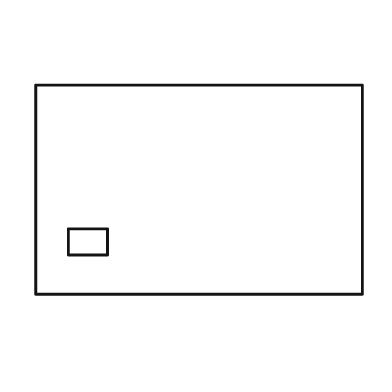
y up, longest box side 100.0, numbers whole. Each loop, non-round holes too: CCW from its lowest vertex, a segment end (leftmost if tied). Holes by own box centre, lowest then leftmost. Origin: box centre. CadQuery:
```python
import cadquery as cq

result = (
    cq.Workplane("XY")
    .moveTo(-50.0, -32.0)
    .lineTo(50.0, -32.0)
    .lineTo(50.0, 32.0)
    .lineTo(-50.0, 32.0)
    .close()
    .moveTo(-40.0, -20.0)
    .lineTo(-28.0, -20.0)
    .lineTo(-28.0, -12.0)
    .lineTo(-40.0, -12.0)
    .close()
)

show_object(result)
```